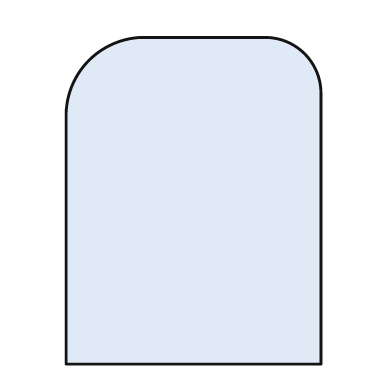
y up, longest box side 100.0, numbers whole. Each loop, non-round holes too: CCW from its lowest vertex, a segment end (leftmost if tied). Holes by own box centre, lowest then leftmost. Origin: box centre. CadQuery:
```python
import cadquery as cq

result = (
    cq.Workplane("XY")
    .moveTo(-39.0, -50.0)
    .lineTo(39.0, -50.0)
    .lineTo(39.0, 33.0)
    .threePointArc((34.0, 45.0), (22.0, 50.0))
    .lineTo(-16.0, 50.0)
    .threePointArc((-32.0, 43.0), (-39.0, 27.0))
    .close()
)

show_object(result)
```